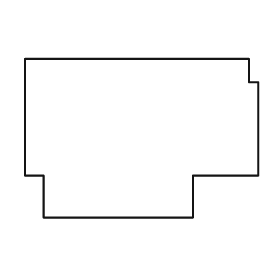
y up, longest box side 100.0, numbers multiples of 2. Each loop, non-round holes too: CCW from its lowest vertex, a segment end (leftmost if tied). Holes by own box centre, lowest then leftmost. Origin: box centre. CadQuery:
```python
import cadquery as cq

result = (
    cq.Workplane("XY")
    .moveTo(-42.0, -34.0)
    .lineTo(22.0, -34.0)
    .lineTo(22.0, -16.0)
    .lineTo(50.0, -16.0)
    .lineTo(50.0, 24.0)
    .lineTo(46.0, 24.0)
    .lineTo(46.0, 34.0)
    .lineTo(-50.0, 34.0)
    .lineTo(-50.0, -16.0)
    .lineTo(-42.0, -16.0)
    .close()
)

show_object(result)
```